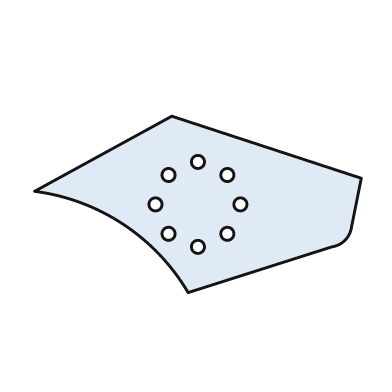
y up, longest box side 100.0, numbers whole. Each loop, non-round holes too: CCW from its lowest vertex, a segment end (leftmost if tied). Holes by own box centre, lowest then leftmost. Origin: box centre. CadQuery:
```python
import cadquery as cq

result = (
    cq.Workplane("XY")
    .moveTo(-3.0, -27.0)
    .lineTo(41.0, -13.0)
    .threePointArc((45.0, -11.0), (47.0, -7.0))
    .lineTo(50.0, 8.0)
    .lineTo(-8.0, 27.0)
    .lineTo(-50.0, 4.0)
    .threePointArc((-23.0, -6.0), (-3.0, -27.0))
    .close()
    .moveTo(0.0, -13.0)
    .circle(2.0)
    .moveTo(-9.0, -9.0)
    .circle(2.0)
    .moveTo(9.0, -9.0)
    .circle(2.0)
    .moveTo(-13.0, 0.0)
    .circle(2.0)
    .moveTo(13.0, 0.0)
    .circle(2.0)
    .moveTo(-9.0, 9.0)
    .circle(2.0)
    .moveTo(9.0, 9.0)
    .circle(2.0)
    .moveTo(0.0, 13.0)
    .circle(2.0)
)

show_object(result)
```